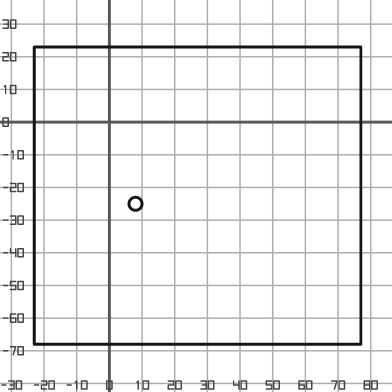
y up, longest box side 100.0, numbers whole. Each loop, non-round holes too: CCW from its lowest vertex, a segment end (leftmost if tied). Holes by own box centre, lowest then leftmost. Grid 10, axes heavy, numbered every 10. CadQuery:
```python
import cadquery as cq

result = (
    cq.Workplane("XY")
    .moveTo(-23.0, -68.0)
    .lineTo(77.0, -68.0)
    .lineTo(77.0, 23.0)
    .lineTo(-23.0, 23.0)
    .close()
    .moveTo(8.0, -25.0)
    .circle(2.0)
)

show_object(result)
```